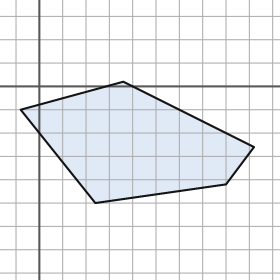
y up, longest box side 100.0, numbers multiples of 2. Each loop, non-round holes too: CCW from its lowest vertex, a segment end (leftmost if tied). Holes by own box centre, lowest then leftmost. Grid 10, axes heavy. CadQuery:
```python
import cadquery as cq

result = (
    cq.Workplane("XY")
    .moveTo(24.0, -50.0)
    .lineTo(80.0, -42.0)
    .lineTo(92.0, -26.0)
    .lineTo(36.0, 2.0)
    .lineTo(-8.0, -10.0)
    .close()
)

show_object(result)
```